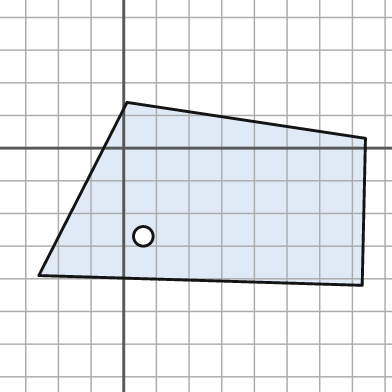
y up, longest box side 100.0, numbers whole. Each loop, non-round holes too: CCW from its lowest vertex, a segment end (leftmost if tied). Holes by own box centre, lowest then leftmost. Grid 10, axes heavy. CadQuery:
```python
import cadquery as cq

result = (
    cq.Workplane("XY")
    .moveTo(73.0, -42.0)
    .lineTo(74.0, 3.0)
    .lineTo(1.0, 14.0)
    .lineTo(-26.0, -39.0)
    .close()
    .moveTo(6.0, -27.0)
    .circle(3.0)
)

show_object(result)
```